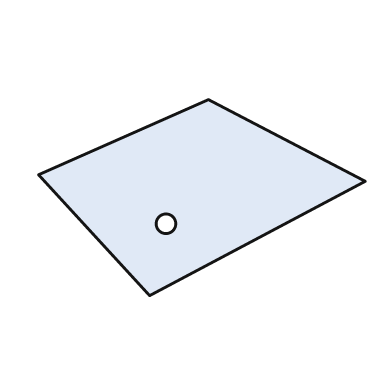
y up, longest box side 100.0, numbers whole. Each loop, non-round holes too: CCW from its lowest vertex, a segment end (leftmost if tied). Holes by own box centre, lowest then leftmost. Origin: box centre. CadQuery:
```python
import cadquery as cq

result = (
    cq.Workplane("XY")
    .moveTo(-16.0, -30.0)
    .lineTo(50.0, 5.0)
    .lineTo(2.0, 30.0)
    .lineTo(-50.0, 7.0)
    .close()
    .moveTo(-11.0, -8.0)
    .circle(3.0)
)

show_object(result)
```